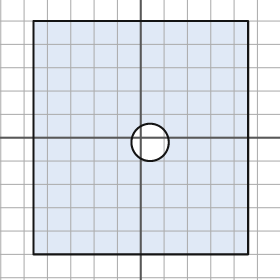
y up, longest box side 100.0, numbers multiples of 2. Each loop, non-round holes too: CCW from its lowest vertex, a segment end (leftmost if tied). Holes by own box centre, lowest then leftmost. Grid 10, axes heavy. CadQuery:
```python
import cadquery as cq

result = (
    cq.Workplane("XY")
    .moveTo(-46.0, -50.0)
    .lineTo(46.0, -50.0)
    .lineTo(46.0, 50.0)
    .lineTo(-46.0, 50.0)
    .close()
    .moveTo(4.0, -2.0)
    .circle(8.0)
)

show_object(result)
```